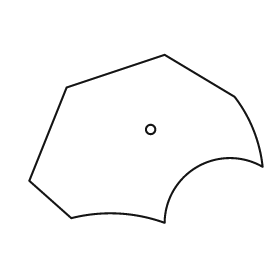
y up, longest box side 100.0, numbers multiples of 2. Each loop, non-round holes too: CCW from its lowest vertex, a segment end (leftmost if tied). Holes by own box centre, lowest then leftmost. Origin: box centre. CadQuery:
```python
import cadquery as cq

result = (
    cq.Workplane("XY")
    .moveTo(8.0, -36.0)
    .threePointArc((22.0, -12.0), (50.0, -12.0))
    .threePointArc((46.0, 4.0), (38.0, 18.0))
    .lineTo(8.0, 36.0)
    .lineTo(-34.0, 22.0)
    .lineTo(-50.0, -18.0)
    .lineTo(-32.0, -34.0)
    .threePointArc((-12.0, -32.0), (8.0, -36.0))
    .close()
    .moveTo(2.0, 4.0)
    .circle(2.0)
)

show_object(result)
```